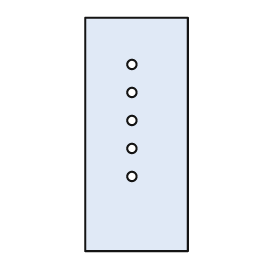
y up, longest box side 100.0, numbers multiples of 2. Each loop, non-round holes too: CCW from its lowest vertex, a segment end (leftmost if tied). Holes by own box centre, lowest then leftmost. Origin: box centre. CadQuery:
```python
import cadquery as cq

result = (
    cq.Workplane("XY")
    .moveTo(-22.0, -50.0)
    .lineTo(22.0, -50.0)
    .lineTo(22.0, 50.0)
    .lineTo(-22.0, 50.0)
    .close()
    .moveTo(-2.0, -18.0)
    .circle(2.0)
    .moveTo(-2.0, -6.0)
    .circle(2.0)
    .moveTo(-2.0, 6.0)
    .circle(2.0)
    .moveTo(-2.0, 18.0)
    .circle(2.0)
    .moveTo(-2.0, 30.0)
    .circle(2.0)
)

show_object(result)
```